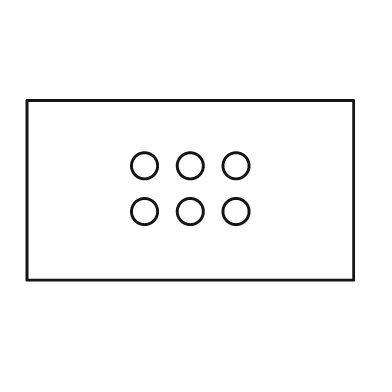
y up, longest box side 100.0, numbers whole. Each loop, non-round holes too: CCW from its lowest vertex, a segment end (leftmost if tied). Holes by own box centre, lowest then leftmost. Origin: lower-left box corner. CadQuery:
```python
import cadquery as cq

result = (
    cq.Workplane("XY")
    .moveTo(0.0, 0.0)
    .lineTo(100.0, 0.0)
    .lineTo(100.0, 55.0)
    .lineTo(0.0, 55.0)
    .close()
    .moveTo(36.0, 21.0)
    .circle(4.0)
    .moveTo(50.0, 21.0)
    .circle(4.0)
    .moveTo(64.0, 21.0)
    .circle(4.0)
    .moveTo(36.0, 35.0)
    .circle(4.0)
    .moveTo(50.0, 35.0)
    .circle(4.0)
    .moveTo(64.0, 35.0)
    .circle(4.0)
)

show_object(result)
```